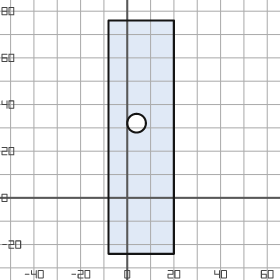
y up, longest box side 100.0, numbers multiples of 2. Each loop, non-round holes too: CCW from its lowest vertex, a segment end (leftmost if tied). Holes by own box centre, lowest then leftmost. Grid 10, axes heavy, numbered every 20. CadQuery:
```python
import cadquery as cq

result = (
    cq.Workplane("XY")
    .moveTo(-8.0, -24.0)
    .lineTo(20.0, -24.0)
    .lineTo(20.0, 76.0)
    .lineTo(-8.0, 76.0)
    .close()
    .moveTo(4.0, 32.0)
    .circle(4.0)
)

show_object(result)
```